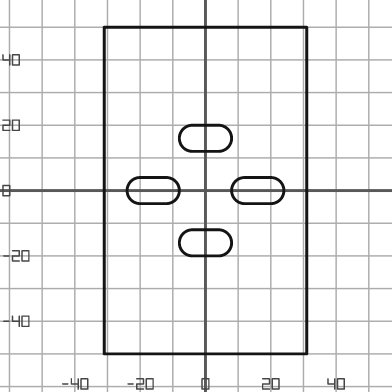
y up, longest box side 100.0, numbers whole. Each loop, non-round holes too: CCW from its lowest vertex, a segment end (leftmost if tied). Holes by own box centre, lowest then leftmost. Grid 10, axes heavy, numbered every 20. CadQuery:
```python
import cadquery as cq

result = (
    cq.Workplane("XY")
    .moveTo(-31.0, -50.0)
    .lineTo(31.0, -50.0)
    .lineTo(31.0, 50.0)
    .lineTo(-31.0, 50.0)
    .close()
    .moveTo(-4.0, -20.0)
    .lineTo(4.0, -20.0)
    .threePointArc((8.0, -16.0), (4.0, -12.0))
    .lineTo(-4.0, -12.0)
    .threePointArc((-8.0, -16.0), (-4.0, -20.0))
    .close()
    .moveTo(-20.0, -4.0)
    .lineTo(-12.0, -4.0)
    .threePointArc((-8.0, 0.0), (-12.0, 4.0))
    .lineTo(-20.0, 4.0)
    .threePointArc((-24.0, 0.0), (-20.0, -4.0))
    .close()
    .moveTo(12.0, -4.0)
    .lineTo(20.0, -4.0)
    .threePointArc((24.0, 0.0), (20.0, 4.0))
    .lineTo(12.0, 4.0)
    .threePointArc((8.0, 0.0), (12.0, -4.0))
    .close()
    .moveTo(-4.0, 12.0)
    .lineTo(4.0, 12.0)
    .threePointArc((8.0, 16.0), (4.0, 20.0))
    .lineTo(-4.0, 20.0)
    .threePointArc((-8.0, 16.0), (-4.0, 12.0))
    .close()
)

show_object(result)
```